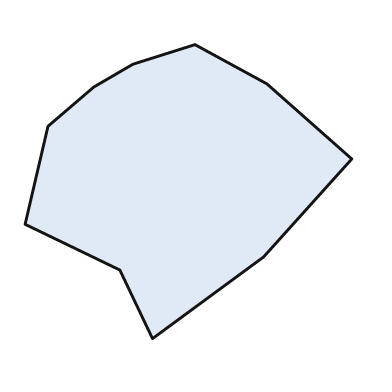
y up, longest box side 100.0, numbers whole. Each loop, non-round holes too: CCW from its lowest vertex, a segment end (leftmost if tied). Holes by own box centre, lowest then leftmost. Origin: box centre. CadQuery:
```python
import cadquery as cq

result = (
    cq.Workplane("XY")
    .moveTo(-11.0, -45.0)
    .lineTo(23.0, -20.0)
    .lineTo(50.0, 10.0)
    .lineTo(24.0, 33.0)
    .lineTo(2.0, 45.0)
    .lineTo(-17.0, 39.0)
    .lineTo(-29.0, 32.0)
    .lineTo(-43.0, 20.0)
    .lineTo(-50.0, -10.0)
    .lineTo(-21.0, -24.0)
    .close()
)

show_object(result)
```